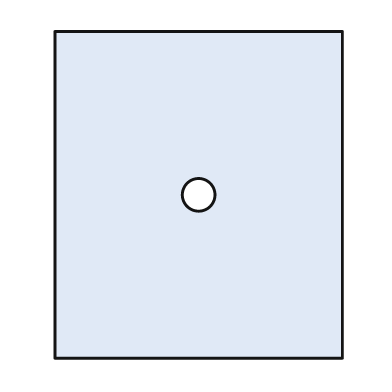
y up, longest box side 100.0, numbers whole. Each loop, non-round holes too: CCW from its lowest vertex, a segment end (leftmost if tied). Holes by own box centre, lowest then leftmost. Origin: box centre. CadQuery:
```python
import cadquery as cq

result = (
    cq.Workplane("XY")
    .moveTo(-44.0, -50.0)
    .lineTo(44.0, -50.0)
    .lineTo(44.0, 50.0)
    .lineTo(-44.0, 50.0)
    .close()
    .moveTo(0.0, 0.0)
    .circle(5.0)
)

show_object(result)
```